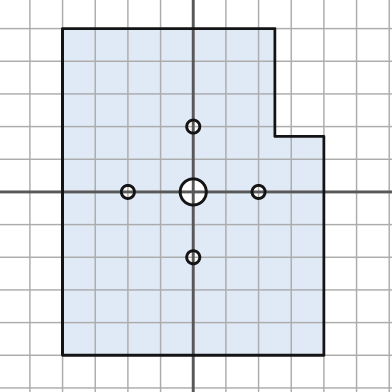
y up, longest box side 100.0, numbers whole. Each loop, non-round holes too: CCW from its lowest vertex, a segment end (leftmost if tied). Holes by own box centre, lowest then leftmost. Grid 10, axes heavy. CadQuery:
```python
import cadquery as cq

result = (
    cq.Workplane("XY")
    .moveTo(-40.0, -50.0)
    .lineTo(40.0, -50.0)
    .lineTo(40.0, 17.0)
    .lineTo(25.0, 17.0)
    .lineTo(25.0, 50.0)
    .lineTo(-40.0, 50.0)
    .close()
    .moveTo(0.0, -20.0)
    .circle(2.0)
    .moveTo(-20.0, 0.0)
    .circle(2.0)
    .moveTo(0.0, 0.0)
    .circle(4.0)
    .moveTo(20.0, 0.0)
    .circle(2.0)
    .moveTo(0.0, 20.0)
    .circle(2.0)
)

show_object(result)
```